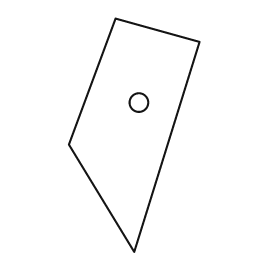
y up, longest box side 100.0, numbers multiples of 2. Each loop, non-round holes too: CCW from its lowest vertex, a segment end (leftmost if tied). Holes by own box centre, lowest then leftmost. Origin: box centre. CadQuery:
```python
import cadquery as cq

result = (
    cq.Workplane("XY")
    .moveTo(0.0, -50.0)
    .lineTo(28.0, 40.0)
    .lineTo(-8.0, 50.0)
    .lineTo(-28.0, -4.0)
    .close()
    .moveTo(2.0, 14.0)
    .circle(4.0)
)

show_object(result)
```